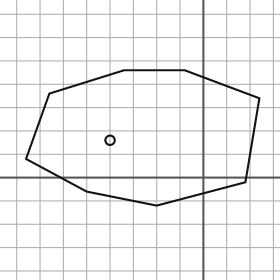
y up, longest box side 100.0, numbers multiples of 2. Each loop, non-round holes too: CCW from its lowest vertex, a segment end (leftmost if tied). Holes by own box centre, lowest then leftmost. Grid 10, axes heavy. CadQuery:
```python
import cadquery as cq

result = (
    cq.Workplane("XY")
    .moveTo(-20.0, -12.0)
    .lineTo(18.0, -2.0)
    .lineTo(24.0, 34.0)
    .lineTo(-8.0, 46.0)
    .lineTo(-34.0, 46.0)
    .lineTo(-66.0, 36.0)
    .lineTo(-76.0, 8.0)
    .lineTo(-50.0, -6.0)
    .close()
    .moveTo(-40.0, 16.0)
    .circle(2.0)
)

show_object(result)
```